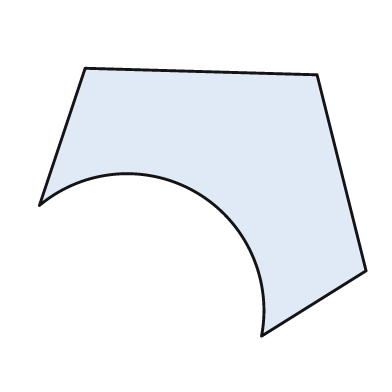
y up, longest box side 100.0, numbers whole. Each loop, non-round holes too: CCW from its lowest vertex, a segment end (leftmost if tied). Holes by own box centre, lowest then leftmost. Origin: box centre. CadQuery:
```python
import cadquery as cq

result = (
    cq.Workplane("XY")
    .moveTo(18.0, -41.0)
    .lineTo(50.0, -21.0)
    .lineTo(35.0, 39.0)
    .lineTo(-36.0, 41.0)
    .lineTo(-50.0, -1.0)
    .threePointArc((-2.0, 3.0), (18.0, -41.0))
    .close()
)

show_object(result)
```